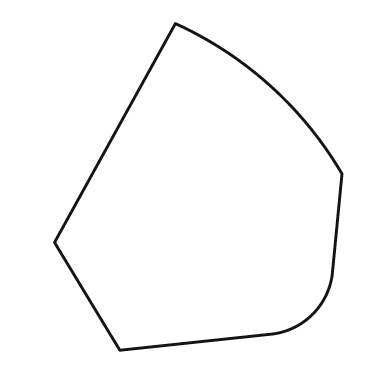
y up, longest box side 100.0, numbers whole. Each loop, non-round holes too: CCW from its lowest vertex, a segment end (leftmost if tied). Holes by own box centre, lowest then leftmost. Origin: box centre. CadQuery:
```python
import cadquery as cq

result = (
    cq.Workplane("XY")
    .moveTo(-24.0, -50.0)
    .lineTo(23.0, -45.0)
    .threePointArc((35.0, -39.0), (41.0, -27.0))
    .lineTo(44.0, 4.0)
    .threePointArc((22.0, 31.0), (-7.0, 50.0))
    .lineTo(-44.0, -17.0)
    .close()
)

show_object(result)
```